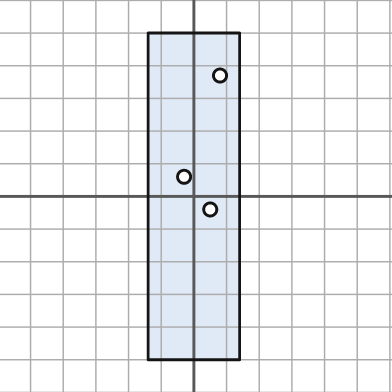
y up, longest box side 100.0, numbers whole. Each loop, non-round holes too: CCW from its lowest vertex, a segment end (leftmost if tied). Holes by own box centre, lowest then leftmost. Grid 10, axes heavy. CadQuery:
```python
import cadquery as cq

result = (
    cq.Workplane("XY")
    .moveTo(-14.0, -50.0)
    .lineTo(14.0, -50.0)
    .lineTo(14.0, 50.0)
    .lineTo(-14.0, 50.0)
    .close()
    .moveTo(5.0, -4.0)
    .circle(2.0)
    .moveTo(-3.0, 6.0)
    .circle(2.0)
    .moveTo(8.0, 37.0)
    .circle(2.0)
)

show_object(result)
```